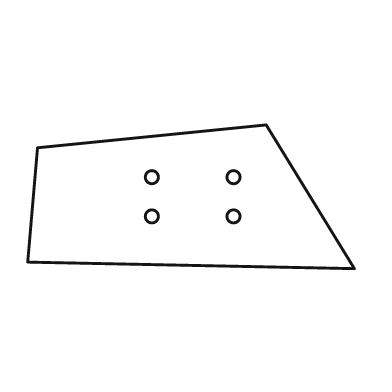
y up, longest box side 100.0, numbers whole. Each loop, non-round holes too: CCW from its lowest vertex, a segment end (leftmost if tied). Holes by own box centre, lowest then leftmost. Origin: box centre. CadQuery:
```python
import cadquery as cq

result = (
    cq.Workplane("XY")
    .moveTo(50.0, -22.0)
    .lineTo(23.0, 22.0)
    .lineTo(-47.0, 15.0)
    .lineTo(-50.0, -20.0)
    .close()
    .moveTo(-12.0, -6.0)
    .circle(2.0)
    .moveTo(13.0, -6.0)
    .circle(2.0)
    .moveTo(-12.0, 6.0)
    .circle(2.0)
    .moveTo(13.0, 6.0)
    .circle(2.0)
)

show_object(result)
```